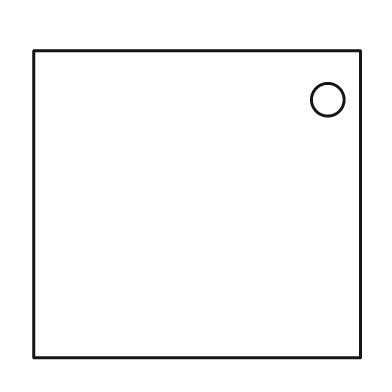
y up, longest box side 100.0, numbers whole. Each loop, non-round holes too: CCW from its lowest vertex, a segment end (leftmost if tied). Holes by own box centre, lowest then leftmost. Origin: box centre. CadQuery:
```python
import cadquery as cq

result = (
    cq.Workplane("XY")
    .moveTo(-50.0, -47.0)
    .lineTo(50.0, -47.0)
    .lineTo(50.0, 47.0)
    .lineTo(-50.0, 47.0)
    .close()
    .moveTo(40.0, 32.0)
    .circle(5.0)
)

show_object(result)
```